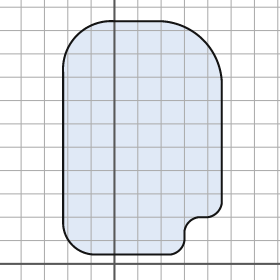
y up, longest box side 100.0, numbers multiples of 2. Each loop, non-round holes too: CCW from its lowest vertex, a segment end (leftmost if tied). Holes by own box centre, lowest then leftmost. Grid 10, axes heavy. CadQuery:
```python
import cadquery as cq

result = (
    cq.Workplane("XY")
    .moveTo(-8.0, 4.0)
    .lineTo(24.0, 4.0)
    .threePointArc((28.0, 6.0), (30.0, 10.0))
    .lineTo(30.0, 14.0)
    .threePointArc((32.0, 18.0), (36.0, 20.0))
    .lineTo(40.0, 20.0)
    .threePointArc((44.0, 22.0), (46.0, 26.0))
    .lineTo(46.0, 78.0)
    .threePointArc((38.0, 96.0), (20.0, 104.0))
    .lineTo(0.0, 104.0)
    .threePointArc((-16.0, 98.0), (-22.0, 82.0))
    .lineTo(-22.0, 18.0)
    .threePointArc((-18.0, 8.0), (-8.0, 4.0))
    .close()
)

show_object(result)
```